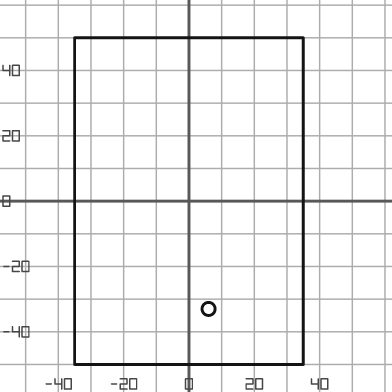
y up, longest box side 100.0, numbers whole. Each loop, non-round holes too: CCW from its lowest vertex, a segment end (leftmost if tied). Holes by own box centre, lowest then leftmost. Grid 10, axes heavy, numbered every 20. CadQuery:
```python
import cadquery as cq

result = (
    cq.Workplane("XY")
    .moveTo(-35.0, -50.0)
    .lineTo(35.0, -50.0)
    .lineTo(35.0, 50.0)
    .lineTo(-35.0, 50.0)
    .close()
    .moveTo(6.0, -33.0)
    .circle(2.0)
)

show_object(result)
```